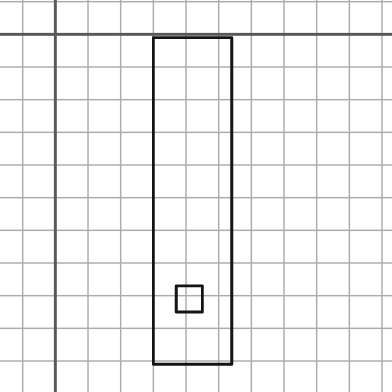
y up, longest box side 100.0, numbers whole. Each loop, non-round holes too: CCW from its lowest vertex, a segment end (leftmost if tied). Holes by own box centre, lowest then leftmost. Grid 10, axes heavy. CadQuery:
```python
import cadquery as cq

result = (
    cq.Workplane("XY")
    .moveTo(30.0, -101.0)
    .lineTo(54.0, -101.0)
    .lineTo(54.0, -1.0)
    .lineTo(30.0, -1.0)
    .close()
    .moveTo(37.0, -85.0)
    .lineTo(45.0, -85.0)
    .lineTo(45.0, -77.0)
    .lineTo(37.0, -77.0)
    .close()
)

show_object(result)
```